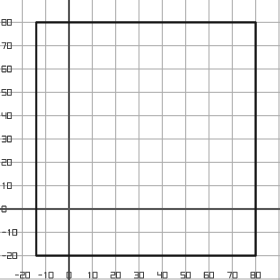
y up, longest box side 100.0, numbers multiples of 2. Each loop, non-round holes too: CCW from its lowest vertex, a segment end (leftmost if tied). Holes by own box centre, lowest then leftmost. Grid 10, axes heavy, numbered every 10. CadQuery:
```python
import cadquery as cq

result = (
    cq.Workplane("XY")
    .moveTo(-14.0, -20.0)
    .lineTo(80.0, -20.0)
    .lineTo(80.0, 80.0)
    .lineTo(-14.0, 80.0)
    .close()
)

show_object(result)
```